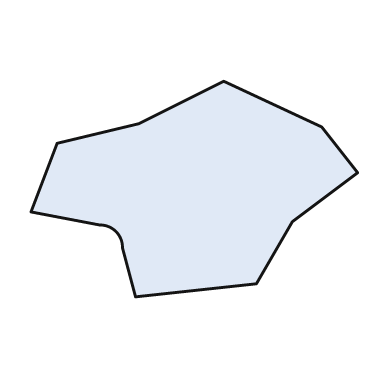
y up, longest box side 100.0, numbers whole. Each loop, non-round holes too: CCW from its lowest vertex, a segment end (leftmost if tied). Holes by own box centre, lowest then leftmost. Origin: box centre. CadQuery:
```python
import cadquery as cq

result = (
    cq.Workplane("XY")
    .moveTo(-18.0, -33.0)
    .lineTo(19.0, -29.0)
    .lineTo(30.0, -10.0)
    .lineTo(50.0, 5.0)
    .lineTo(39.0, 19.0)
    .lineTo(9.0, 33.0)
    .lineTo(-17.0, 20.0)
    .lineTo(-42.0, 14.0)
    .lineTo(-50.0, -7.0)
    .lineTo(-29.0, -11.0)
    .threePointArc((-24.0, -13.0), (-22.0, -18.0))
    .close()
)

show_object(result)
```